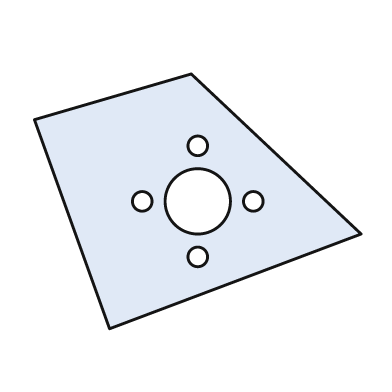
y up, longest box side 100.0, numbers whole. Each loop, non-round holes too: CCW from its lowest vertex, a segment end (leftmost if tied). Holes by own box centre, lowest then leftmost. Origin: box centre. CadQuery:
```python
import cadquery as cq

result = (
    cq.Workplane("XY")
    .moveTo(-27.0, -39.0)
    .lineTo(50.0, -10.0)
    .lineTo(-2.0, 39.0)
    .lineTo(-50.0, 25.0)
    .close()
    .moveTo(0.0, -17.0)
    .circle(3.0)
    .moveTo(-17.0, 0.0)
    .circle(3.0)
    .moveTo(0.0, 0.0)
    .circle(10.0)
    .moveTo(17.0, 0.0)
    .circle(3.0)
    .moveTo(0.0, 17.0)
    .circle(3.0)
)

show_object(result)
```